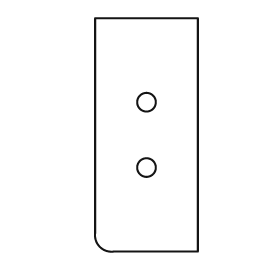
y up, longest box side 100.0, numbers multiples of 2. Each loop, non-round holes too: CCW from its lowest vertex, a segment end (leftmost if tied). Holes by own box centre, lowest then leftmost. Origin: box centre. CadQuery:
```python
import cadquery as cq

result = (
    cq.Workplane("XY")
    .moveTo(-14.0, -50.0)
    .lineTo(22.0, -50.0)
    .lineTo(22.0, 50.0)
    .lineTo(-22.0, 50.0)
    .lineTo(-22.0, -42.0)
    .threePointArc((-20.0, -48.0), (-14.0, -50.0))
    .close()
    .moveTo(0.0, -14.0)
    .circle(4.0)
    .moveTo(0.0, 14.0)
    .circle(4.0)
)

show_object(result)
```